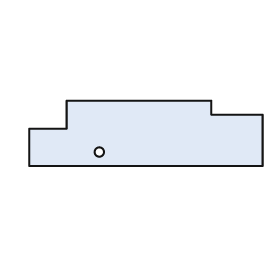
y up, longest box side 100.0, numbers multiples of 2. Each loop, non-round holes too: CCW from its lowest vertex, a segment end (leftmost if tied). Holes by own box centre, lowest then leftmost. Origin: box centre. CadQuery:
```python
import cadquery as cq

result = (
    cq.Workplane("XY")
    .moveTo(-50.0, -14.0)
    .lineTo(50.0, -14.0)
    .lineTo(50.0, 8.0)
    .lineTo(28.0, 8.0)
    .lineTo(28.0, 14.0)
    .lineTo(-34.0, 14.0)
    .lineTo(-34.0, 2.0)
    .lineTo(-50.0, 2.0)
    .close()
    .moveTo(-20.0, -8.0)
    .circle(2.0)
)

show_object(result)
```